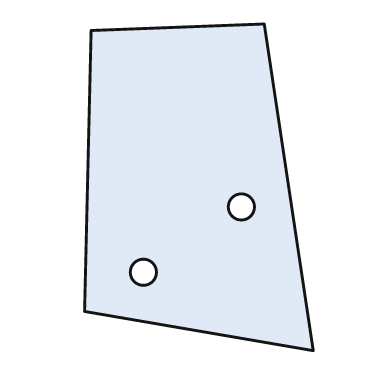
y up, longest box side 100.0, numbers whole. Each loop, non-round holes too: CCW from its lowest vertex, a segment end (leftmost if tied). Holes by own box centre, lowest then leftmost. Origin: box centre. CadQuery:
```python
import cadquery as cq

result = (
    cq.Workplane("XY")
    .moveTo(35.0, -50.0)
    .lineTo(20.0, 50.0)
    .lineTo(-33.0, 48.0)
    .lineTo(-35.0, -38.0)
    .close()
    .moveTo(-17.0, -26.0)
    .circle(4.0)
    .moveTo(13.0, -6.0)
    .circle(4.0)
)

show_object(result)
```